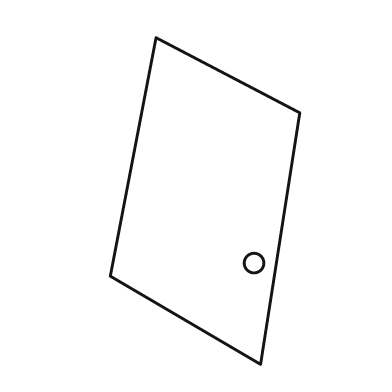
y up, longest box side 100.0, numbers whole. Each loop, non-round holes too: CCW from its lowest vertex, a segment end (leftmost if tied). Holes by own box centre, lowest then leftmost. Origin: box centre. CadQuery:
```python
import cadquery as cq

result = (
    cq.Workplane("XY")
    .moveTo(17.0, -50.0)
    .lineTo(29.0, 27.0)
    .lineTo(-15.0, 50.0)
    .lineTo(-29.0, -23.0)
    .close()
    .moveTo(15.0, -19.0)
    .circle(3.0)
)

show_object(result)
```